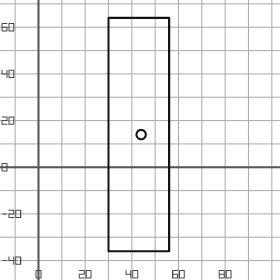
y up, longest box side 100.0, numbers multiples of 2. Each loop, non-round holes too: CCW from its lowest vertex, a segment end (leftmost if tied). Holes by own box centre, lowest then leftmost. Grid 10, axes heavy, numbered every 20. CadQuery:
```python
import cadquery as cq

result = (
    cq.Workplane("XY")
    .moveTo(30.0, -36.0)
    .lineTo(56.0, -36.0)
    .lineTo(56.0, 64.0)
    .lineTo(30.0, 64.0)
    .close()
    .moveTo(44.0, 14.0)
    .circle(2.0)
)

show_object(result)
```